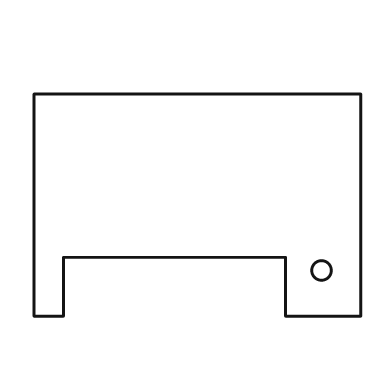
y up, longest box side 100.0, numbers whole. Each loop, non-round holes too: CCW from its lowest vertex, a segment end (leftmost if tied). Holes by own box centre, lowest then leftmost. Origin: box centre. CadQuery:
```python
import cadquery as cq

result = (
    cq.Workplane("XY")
    .moveTo(-50.0, -34.0)
    .lineTo(-41.0, -34.0)
    .lineTo(-41.0, -16.0)
    .lineTo(27.0, -16.0)
    .lineTo(27.0, -34.0)
    .lineTo(50.0, -34.0)
    .lineTo(50.0, 34.0)
    .lineTo(-50.0, 34.0)
    .close()
    .moveTo(38.0, -20.0)
    .circle(3.0)
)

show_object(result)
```